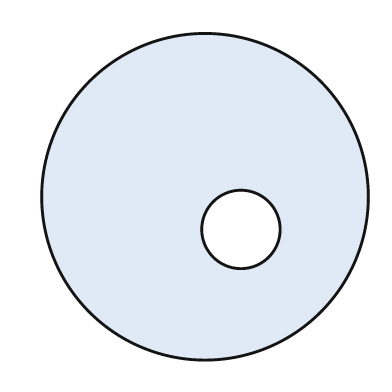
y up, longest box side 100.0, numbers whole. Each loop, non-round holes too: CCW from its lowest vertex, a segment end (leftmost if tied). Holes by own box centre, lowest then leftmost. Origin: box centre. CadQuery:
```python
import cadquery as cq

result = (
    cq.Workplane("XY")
    .moveTo(0.0, 0.0)
    .circle(50.0)
    .moveTo(11.0, -10.0)
    .circle(12.0)
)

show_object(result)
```